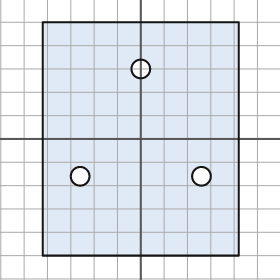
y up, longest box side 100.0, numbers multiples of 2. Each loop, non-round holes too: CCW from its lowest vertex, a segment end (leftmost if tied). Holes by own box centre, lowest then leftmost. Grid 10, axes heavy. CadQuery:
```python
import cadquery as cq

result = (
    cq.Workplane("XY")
    .moveTo(-42.0, -50.0)
    .lineTo(42.0, -50.0)
    .lineTo(42.0, 50.0)
    .lineTo(-42.0, 50.0)
    .close()
    .moveTo(-26.0, -16.0)
    .circle(4.0)
    .moveTo(26.0, -16.0)
    .circle(4.0)
    .moveTo(0.0, 30.0)
    .circle(4.0)
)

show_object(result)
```